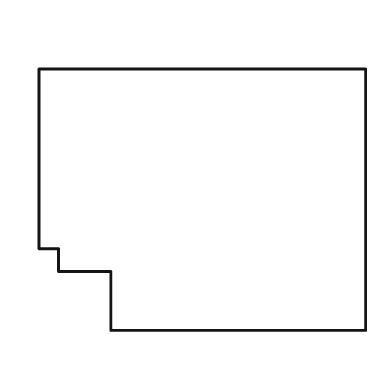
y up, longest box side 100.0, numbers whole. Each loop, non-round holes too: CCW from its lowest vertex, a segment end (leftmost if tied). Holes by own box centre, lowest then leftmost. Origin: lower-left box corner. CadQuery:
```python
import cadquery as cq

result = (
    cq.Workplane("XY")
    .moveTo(22.0, 0.0)
    .lineTo(100.0, 0.0)
    .lineTo(100.0, 80.0)
    .lineTo(0.0, 80.0)
    .lineTo(0.0, 25.0)
    .lineTo(6.0, 25.0)
    .lineTo(6.0, 18.0)
    .lineTo(22.0, 18.0)
    .close()
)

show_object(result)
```